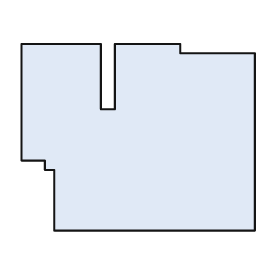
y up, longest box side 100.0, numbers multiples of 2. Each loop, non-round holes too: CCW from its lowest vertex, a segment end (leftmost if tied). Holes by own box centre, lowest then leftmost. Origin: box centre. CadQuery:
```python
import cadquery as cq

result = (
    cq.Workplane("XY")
    .moveTo(-36.0, -40.0)
    .lineTo(50.0, -40.0)
    .lineTo(50.0, 36.0)
    .lineTo(18.0, 36.0)
    .lineTo(18.0, 40.0)
    .lineTo(-10.0, 40.0)
    .lineTo(-10.0, 12.0)
    .lineTo(-16.0, 12.0)
    .lineTo(-16.0, 40.0)
    .lineTo(-50.0, 40.0)
    .lineTo(-50.0, -10.0)
    .lineTo(-40.0, -10.0)
    .lineTo(-40.0, -14.0)
    .lineTo(-36.0, -14.0)
    .close()
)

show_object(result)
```